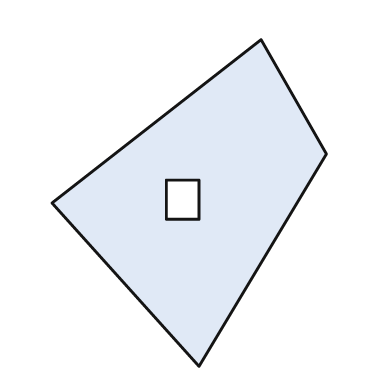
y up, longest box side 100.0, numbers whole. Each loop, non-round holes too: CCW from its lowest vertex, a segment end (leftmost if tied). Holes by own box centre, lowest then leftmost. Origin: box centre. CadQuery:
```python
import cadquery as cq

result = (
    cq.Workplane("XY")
    .moveTo(3.0, -50.0)
    .lineTo(42.0, 15.0)
    .lineTo(22.0, 50.0)
    .lineTo(-42.0, 0.0)
    .close()
    .moveTo(-7.0, -5.0)
    .lineTo(3.0, -5.0)
    .lineTo(3.0, 7.0)
    .lineTo(-7.0, 7.0)
    .close()
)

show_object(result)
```